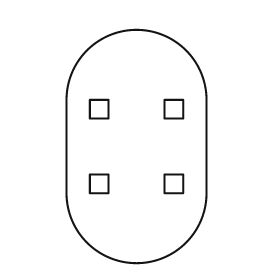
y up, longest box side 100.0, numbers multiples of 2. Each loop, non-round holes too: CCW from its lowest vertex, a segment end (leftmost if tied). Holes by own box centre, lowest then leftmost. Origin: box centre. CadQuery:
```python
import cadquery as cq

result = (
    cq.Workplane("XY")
    .moveTo(-30.0, -20.0)
    .threePointArc((0.0, -50.0), (30.0, -20.0))
    .lineTo(30.0, 20.0)
    .threePointArc((0.0, 50.0), (-30.0, 20.0))
    .close()
    .moveTo(-20.0, -20.0)
    .lineTo(-12.0, -20.0)
    .lineTo(-12.0, -12.0)
    .lineTo(-20.0, -12.0)
    .close()
    .moveTo(12.0, -20.0)
    .lineTo(20.0, -20.0)
    .lineTo(20.0, -12.0)
    .lineTo(12.0, -12.0)
    .close()
    .moveTo(-20.0, 12.0)
    .lineTo(-12.0, 12.0)
    .lineTo(-12.0, 20.0)
    .lineTo(-20.0, 20.0)
    .close()
    .moveTo(12.0, 12.0)
    .lineTo(20.0, 12.0)
    .lineTo(20.0, 20.0)
    .lineTo(12.0, 20.0)
    .close()
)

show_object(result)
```